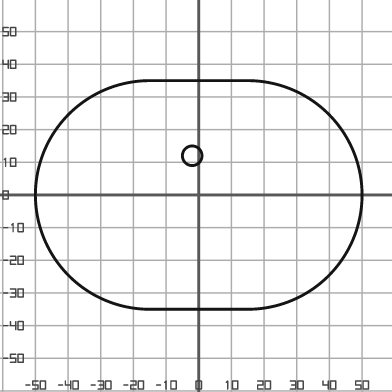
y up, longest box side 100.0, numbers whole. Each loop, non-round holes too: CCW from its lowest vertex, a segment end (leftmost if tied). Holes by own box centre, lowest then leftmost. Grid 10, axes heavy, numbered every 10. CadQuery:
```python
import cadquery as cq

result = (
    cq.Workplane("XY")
    .moveTo(-15.0, -35.0)
    .lineTo(15.0, -35.0)
    .threePointArc((50.0, 0.0), (15.0, 35.0))
    .lineTo(-15.0, 35.0)
    .threePointArc((-50.0, 0.0), (-15.0, -35.0))
    .close()
    .moveTo(-2.0, 12.0)
    .circle(3.0)
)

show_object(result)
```